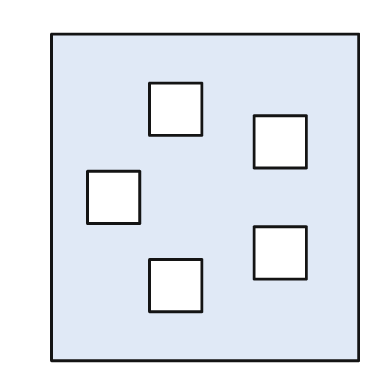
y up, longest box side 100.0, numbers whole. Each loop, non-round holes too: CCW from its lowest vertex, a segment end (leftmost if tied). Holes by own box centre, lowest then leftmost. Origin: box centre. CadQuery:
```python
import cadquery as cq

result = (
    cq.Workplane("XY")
    .moveTo(-47.0, -50.0)
    .lineTo(47.0, -50.0)
    .lineTo(47.0, 50.0)
    .lineTo(-47.0, 50.0)
    .close()
    .moveTo(-17.0, -35.0)
    .lineTo(-1.0, -35.0)
    .lineTo(-1.0, -19.0)
    .lineTo(-17.0, -19.0)
    .close()
    .moveTo(15.0, -25.0)
    .lineTo(31.0, -25.0)
    .lineTo(31.0, -9.0)
    .lineTo(15.0, -9.0)
    .close()
    .moveTo(-36.0, -8.0)
    .lineTo(-20.0, -8.0)
    .lineTo(-20.0, 8.0)
    .lineTo(-36.0, 8.0)
    .close()
    .moveTo(15.0, 9.0)
    .lineTo(31.0, 9.0)
    .lineTo(31.0, 25.0)
    .lineTo(15.0, 25.0)
    .close()
    .moveTo(-17.0, 19.0)
    .lineTo(-1.0, 19.0)
    .lineTo(-1.0, 35.0)
    .lineTo(-17.0, 35.0)
    .close()
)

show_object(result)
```